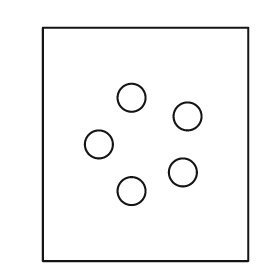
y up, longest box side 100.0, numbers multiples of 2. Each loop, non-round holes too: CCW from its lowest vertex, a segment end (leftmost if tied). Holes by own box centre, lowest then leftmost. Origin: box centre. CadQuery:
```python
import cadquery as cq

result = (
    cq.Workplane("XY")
    .moveTo(-44.0, -50.0)
    .lineTo(44.0, -50.0)
    .lineTo(44.0, 50.0)
    .lineTo(-44.0, 50.0)
    .close()
    .moveTo(-6.0, -20.0)
    .circle(6.0)
    .moveTo(16.0, -12.0)
    .circle(6.0)
    .moveTo(-20.0, 0.0)
    .circle(6.0)
    .moveTo(18.0, 12.0)
    .circle(6.0)
    .moveTo(-6.0, 20.0)
    .circle(6.0)
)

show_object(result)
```